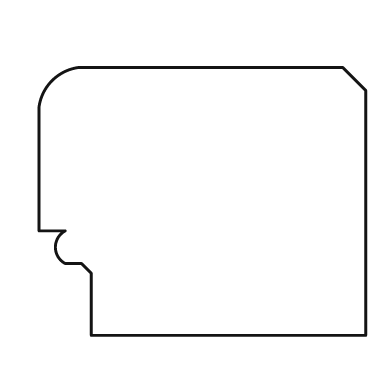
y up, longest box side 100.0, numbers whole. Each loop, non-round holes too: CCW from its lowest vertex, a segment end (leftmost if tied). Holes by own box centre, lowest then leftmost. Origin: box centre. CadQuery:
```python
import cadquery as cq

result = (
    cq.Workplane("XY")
    .moveTo(-34.0, -41.0)
    .lineTo(50.0, -41.0)
    .lineTo(50.0, 34.0)
    .lineTo(43.0, 41.0)
    .lineTo(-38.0, 41.0)
    .threePointArc((-46.0, 37.0), (-50.0, 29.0))
    .lineTo(-50.0, -9.0)
    .lineTo(-42.0, -9.0)
    .threePointArc((-45.0, -14.0), (-42.0, -19.0))
    .lineTo(-37.0, -19.0)
    .lineTo(-34.0, -22.0)
    .close()
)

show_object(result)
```